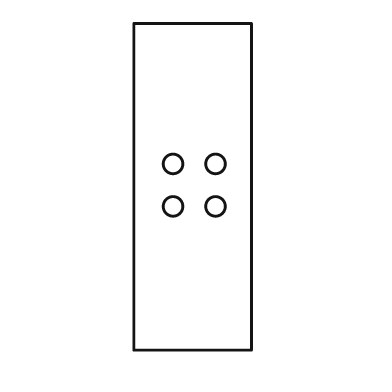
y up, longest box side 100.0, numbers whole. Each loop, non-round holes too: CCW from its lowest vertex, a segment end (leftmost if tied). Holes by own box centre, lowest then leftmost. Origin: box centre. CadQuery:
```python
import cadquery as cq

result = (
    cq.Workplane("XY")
    .moveTo(-18.0, -50.0)
    .lineTo(18.0, -50.0)
    .lineTo(18.0, 50.0)
    .lineTo(-18.0, 50.0)
    .close()
    .moveTo(-6.0, -6.0)
    .circle(3.0)
    .moveTo(7.0, -6.0)
    .circle(3.0)
    .moveTo(-6.0, 7.0)
    .circle(3.0)
    .moveTo(7.0, 7.0)
    .circle(3.0)
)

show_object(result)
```